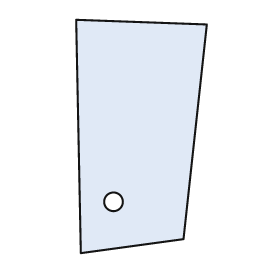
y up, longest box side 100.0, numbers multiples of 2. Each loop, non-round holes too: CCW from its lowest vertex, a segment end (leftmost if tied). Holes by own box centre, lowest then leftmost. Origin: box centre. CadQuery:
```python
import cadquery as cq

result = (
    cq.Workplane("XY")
    .moveTo(-26.0, -50.0)
    .lineTo(18.0, -44.0)
    .lineTo(28.0, 48.0)
    .lineTo(-28.0, 50.0)
    .close()
    .moveTo(-12.0, -28.0)
    .circle(4.0)
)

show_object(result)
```